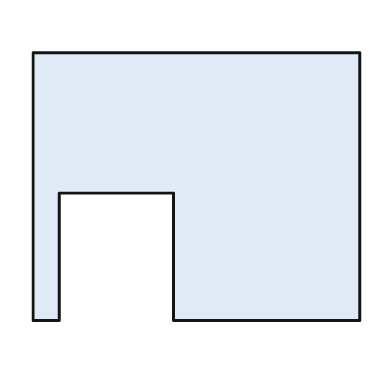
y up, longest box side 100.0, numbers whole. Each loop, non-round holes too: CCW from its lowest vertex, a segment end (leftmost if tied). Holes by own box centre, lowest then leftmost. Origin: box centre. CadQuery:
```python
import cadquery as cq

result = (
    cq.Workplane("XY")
    .moveTo(-50.0, -41.0)
    .lineTo(-42.0, -41.0)
    .lineTo(-42.0, -2.0)
    .lineTo(-7.0, -2.0)
    .lineTo(-7.0, -41.0)
    .lineTo(50.0, -41.0)
    .lineTo(50.0, 41.0)
    .lineTo(-50.0, 41.0)
    .close()
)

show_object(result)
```